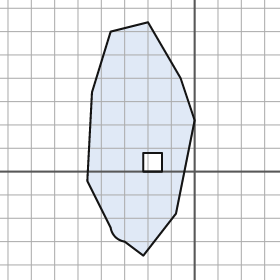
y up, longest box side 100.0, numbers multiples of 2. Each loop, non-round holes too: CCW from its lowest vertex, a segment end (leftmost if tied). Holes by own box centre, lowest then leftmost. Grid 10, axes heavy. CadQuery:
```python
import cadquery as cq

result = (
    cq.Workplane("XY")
    .moveTo(-22.0, -36.0)
    .lineTo(-8.0, -18.0)
    .lineTo(0.0, 22.0)
    .lineTo(-6.0, 40.0)
    .lineTo(-20.0, 64.0)
    .lineTo(-36.0, 60.0)
    .lineTo(-44.0, 34.0)
    .lineTo(-46.0, -4.0)
    .lineTo(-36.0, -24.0)
    .threePointArc((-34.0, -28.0), (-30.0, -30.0))
    .close()
    .moveTo(-22.0, 0.0)
    .lineTo(-14.0, 0.0)
    .lineTo(-14.0, 8.0)
    .lineTo(-22.0, 8.0)
    .close()
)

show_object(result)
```